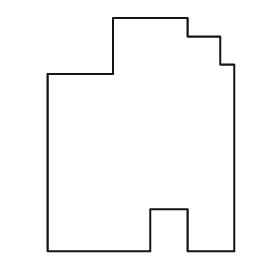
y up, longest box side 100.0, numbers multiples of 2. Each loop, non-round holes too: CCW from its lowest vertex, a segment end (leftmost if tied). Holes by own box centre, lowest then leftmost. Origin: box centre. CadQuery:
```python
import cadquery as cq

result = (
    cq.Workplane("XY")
    .moveTo(-40.0, -50.0)
    .lineTo(4.0, -50.0)
    .lineTo(4.0, -32.0)
    .lineTo(20.0, -32.0)
    .lineTo(20.0, -50.0)
    .lineTo(40.0, -50.0)
    .lineTo(40.0, 30.0)
    .lineTo(34.0, 30.0)
    .lineTo(34.0, 42.0)
    .lineTo(20.0, 42.0)
    .lineTo(20.0, 50.0)
    .lineTo(-12.0, 50.0)
    .lineTo(-12.0, 26.0)
    .lineTo(-40.0, 26.0)
    .close()
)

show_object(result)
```